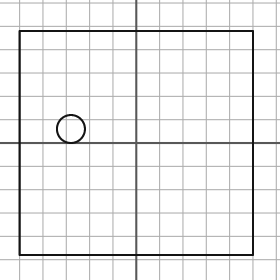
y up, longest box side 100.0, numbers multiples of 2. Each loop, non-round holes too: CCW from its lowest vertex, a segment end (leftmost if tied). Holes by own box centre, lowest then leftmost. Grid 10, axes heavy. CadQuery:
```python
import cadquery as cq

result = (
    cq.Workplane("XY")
    .moveTo(-50.0, -48.0)
    .lineTo(50.0, -48.0)
    .lineTo(50.0, 48.0)
    .lineTo(-50.0, 48.0)
    .close()
    .moveTo(-28.0, 6.0)
    .circle(6.0)
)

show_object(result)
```